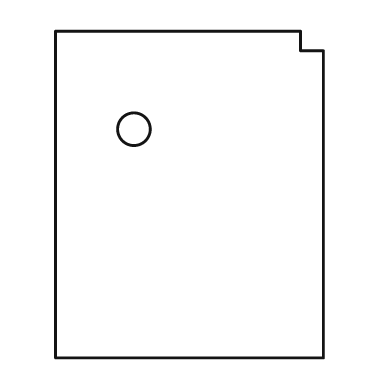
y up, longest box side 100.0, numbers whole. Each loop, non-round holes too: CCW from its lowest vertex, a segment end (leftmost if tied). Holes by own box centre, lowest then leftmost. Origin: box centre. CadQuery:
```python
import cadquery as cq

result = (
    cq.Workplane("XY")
    .moveTo(-41.0, -50.0)
    .lineTo(41.0, -50.0)
    .lineTo(41.0, 44.0)
    .lineTo(34.0, 44.0)
    .lineTo(34.0, 50.0)
    .lineTo(-41.0, 50.0)
    .close()
    .moveTo(-17.0, 20.0)
    .circle(5.0)
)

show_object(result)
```